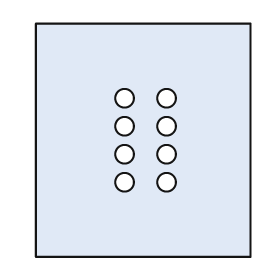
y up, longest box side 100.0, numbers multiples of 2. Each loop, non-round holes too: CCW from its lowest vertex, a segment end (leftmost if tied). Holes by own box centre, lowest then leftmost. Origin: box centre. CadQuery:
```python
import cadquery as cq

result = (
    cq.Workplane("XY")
    .moveTo(-46.0, -50.0)
    .lineTo(46.0, -50.0)
    .lineTo(46.0, 50.0)
    .lineTo(-46.0, 50.0)
    .close()
    .moveTo(-8.0, -18.0)
    .circle(4.0)
    .moveTo(10.0, -18.0)
    .circle(4.0)
    .moveTo(-8.0, -6.0)
    .circle(4.0)
    .moveTo(10.0, -6.0)
    .circle(4.0)
    .moveTo(-8.0, 6.0)
    .circle(4.0)
    .moveTo(10.0, 6.0)
    .circle(4.0)
    .moveTo(-8.0, 18.0)
    .circle(4.0)
    .moveTo(10.0, 18.0)
    .circle(4.0)
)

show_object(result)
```